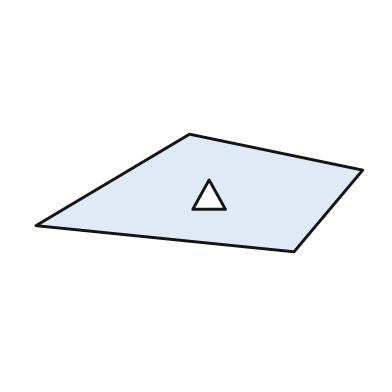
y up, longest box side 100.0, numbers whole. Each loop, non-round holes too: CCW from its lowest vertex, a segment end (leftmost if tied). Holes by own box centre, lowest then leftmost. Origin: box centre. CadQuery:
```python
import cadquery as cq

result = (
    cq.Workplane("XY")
    .moveTo(29.0, -18.0)
    .lineTo(50.0, 7.0)
    .lineTo(-3.0, 18.0)
    .lineTo(-50.0, -10.0)
    .close()
    .moveTo(-2.0, -5.0)
    .lineTo(8.0, -5.0)
    .lineTo(3.0, 4.0)
    .close()
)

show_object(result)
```